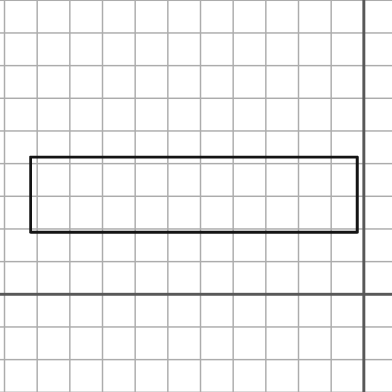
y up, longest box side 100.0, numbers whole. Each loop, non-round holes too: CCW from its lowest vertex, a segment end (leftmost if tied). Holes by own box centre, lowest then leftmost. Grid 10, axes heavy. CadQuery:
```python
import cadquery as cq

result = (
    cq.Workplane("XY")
    .moveTo(-102.0, 19.0)
    .lineTo(-2.0, 19.0)
    .lineTo(-2.0, 42.0)
    .lineTo(-102.0, 42.0)
    .close()
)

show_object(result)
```